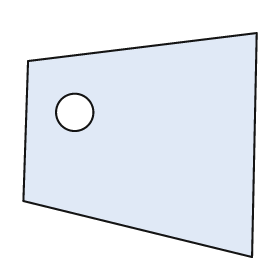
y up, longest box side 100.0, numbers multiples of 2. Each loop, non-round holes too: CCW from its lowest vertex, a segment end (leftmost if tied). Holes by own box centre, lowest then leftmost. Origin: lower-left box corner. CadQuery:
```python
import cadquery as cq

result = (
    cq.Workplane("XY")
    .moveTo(98.0, 0.0)
    .lineTo(100.0, 96.0)
    .lineTo(2.0, 84.0)
    .lineTo(0.0, 24.0)
    .close()
    .moveTo(22.0, 62.0)
    .circle(8.0)
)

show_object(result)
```